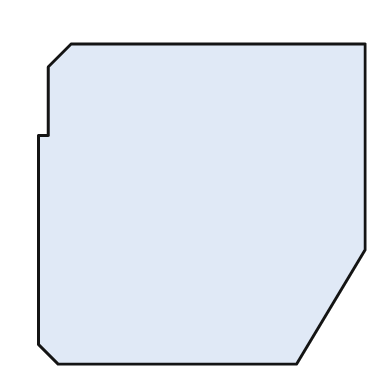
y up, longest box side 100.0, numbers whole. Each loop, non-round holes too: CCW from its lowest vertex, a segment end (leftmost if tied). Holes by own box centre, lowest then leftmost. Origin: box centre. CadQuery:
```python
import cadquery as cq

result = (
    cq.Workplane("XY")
    .moveTo(-44.0, -49.0)
    .lineTo(29.0, -49.0)
    .lineTo(50.0, -14.0)
    .lineTo(50.0, 49.0)
    .lineTo(-40.0, 49.0)
    .lineTo(-47.0, 42.0)
    .lineTo(-47.0, 21.0)
    .lineTo(-50.0, 21.0)
    .lineTo(-50.0, -43.0)
    .close()
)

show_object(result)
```